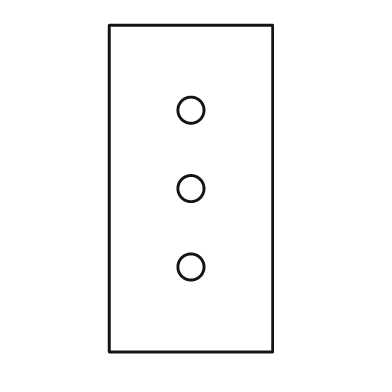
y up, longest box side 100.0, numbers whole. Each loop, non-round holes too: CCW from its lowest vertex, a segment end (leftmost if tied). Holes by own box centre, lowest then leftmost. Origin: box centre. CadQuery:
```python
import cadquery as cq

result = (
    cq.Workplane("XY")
    .moveTo(-25.0, -50.0)
    .lineTo(25.0, -50.0)
    .lineTo(25.0, 50.0)
    .lineTo(-25.0, 50.0)
    .close()
    .moveTo(0.0, -24.0)
    .circle(4.0)
    .moveTo(0.0, 0.0)
    .circle(4.0)
    .moveTo(0.0, 24.0)
    .circle(4.0)
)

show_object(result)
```